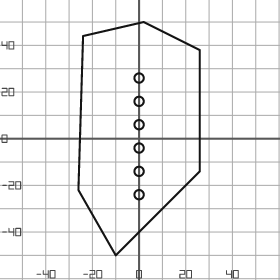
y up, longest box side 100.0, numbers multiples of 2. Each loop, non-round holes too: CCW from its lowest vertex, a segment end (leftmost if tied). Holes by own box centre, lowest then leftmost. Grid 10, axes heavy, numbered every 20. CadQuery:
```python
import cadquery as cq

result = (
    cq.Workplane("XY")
    .moveTo(-10.0, -50.0)
    .lineTo(26.0, -14.0)
    .lineTo(26.0, 38.0)
    .lineTo(2.0, 50.0)
    .lineTo(-24.0, 44.0)
    .lineTo(-26.0, -22.0)
    .close()
    .moveTo(0.0, -24.0)
    .circle(2.0)
    .moveTo(0.0, -14.0)
    .circle(2.0)
    .moveTo(0.0, -4.0)
    .circle(2.0)
    .moveTo(0.0, 6.0)
    .circle(2.0)
    .moveTo(0.0, 16.0)
    .circle(2.0)
    .moveTo(0.0, 26.0)
    .circle(2.0)
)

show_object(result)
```